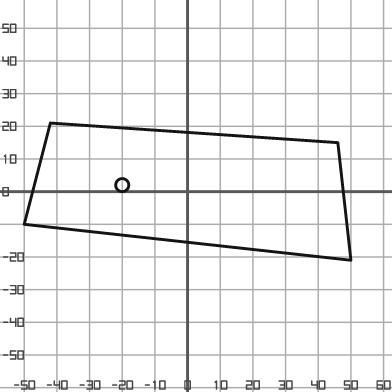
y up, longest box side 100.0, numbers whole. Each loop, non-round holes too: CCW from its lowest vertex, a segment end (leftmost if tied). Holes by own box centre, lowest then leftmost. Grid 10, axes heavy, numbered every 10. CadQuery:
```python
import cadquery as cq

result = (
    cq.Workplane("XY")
    .moveTo(50.0, -21.0)
    .lineTo(46.0, 15.0)
    .lineTo(-42.0, 21.0)
    .lineTo(-50.0, -10.0)
    .close()
    .moveTo(-20.0, 2.0)
    .circle(2.0)
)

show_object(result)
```